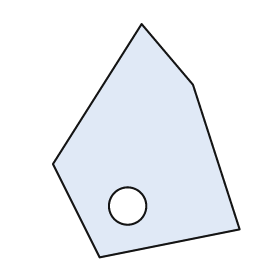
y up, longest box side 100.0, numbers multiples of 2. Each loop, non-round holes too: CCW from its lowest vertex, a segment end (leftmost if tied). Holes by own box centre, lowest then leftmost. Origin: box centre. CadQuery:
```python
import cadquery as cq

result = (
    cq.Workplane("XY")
    .moveTo(-20.0, -50.0)
    .lineTo(40.0, -38.0)
    .lineTo(20.0, 24.0)
    .lineTo(-2.0, 50.0)
    .lineTo(-40.0, -10.0)
    .close()
    .moveTo(-8.0, -28.0)
    .circle(8.0)
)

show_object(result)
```